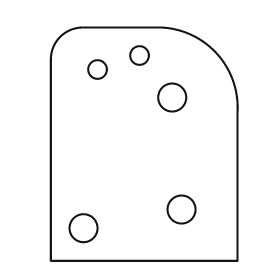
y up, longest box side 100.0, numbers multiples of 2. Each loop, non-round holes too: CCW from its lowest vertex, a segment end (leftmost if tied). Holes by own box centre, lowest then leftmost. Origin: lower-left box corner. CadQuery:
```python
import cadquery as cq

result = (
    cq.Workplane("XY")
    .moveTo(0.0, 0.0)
    .lineTo(80.0, 0.0)
    .lineTo(80.0, 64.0)
    .threePointArc((70.0, 90.0), (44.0, 100.0))
    .lineTo(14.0, 100.0)
    .threePointArc((4.0, 96.0), (0.0, 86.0))
    .close()
    .moveTo(14.0, 14.0)
    .circle(6.0)
    .moveTo(56.0, 22.0)
    .circle(6.0)
    .moveTo(52.0, 70.0)
    .circle(6.0)
    .moveTo(20.0, 82.0)
    .circle(4.0)
    .moveTo(38.0, 88.0)
    .circle(4.0)
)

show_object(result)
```